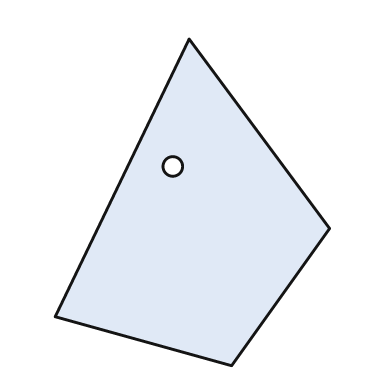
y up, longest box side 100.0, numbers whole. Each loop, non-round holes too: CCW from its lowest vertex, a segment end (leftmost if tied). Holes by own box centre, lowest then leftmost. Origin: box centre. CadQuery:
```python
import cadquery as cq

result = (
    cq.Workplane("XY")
    .moveTo(12.0, -50.0)
    .lineTo(42.0, -8.0)
    .lineTo(-1.0, 50.0)
    .lineTo(-42.0, -35.0)
    .close()
    .moveTo(-6.0, 11.0)
    .circle(3.0)
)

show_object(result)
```